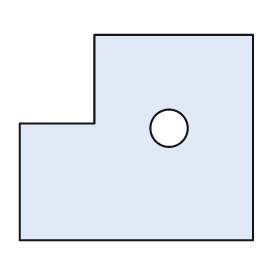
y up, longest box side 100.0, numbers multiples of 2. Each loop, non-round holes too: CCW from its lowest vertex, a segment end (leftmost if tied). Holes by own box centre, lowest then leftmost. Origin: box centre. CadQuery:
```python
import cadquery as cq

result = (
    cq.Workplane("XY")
    .moveTo(-50.0, -44.0)
    .lineTo(50.0, -44.0)
    .lineTo(50.0, 44.0)
    .lineTo(-18.0, 44.0)
    .lineTo(-18.0, 6.0)
    .lineTo(-50.0, 6.0)
    .close()
    .moveTo(14.0, 4.0)
    .circle(8.0)
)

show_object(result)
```